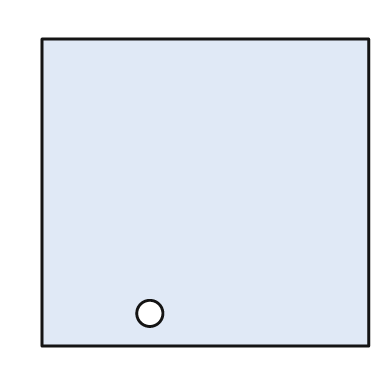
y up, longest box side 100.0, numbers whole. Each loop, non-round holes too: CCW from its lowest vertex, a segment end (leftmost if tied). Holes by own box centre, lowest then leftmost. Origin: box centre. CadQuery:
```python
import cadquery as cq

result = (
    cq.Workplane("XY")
    .moveTo(-50.0, -47.0)
    .lineTo(50.0, -47.0)
    .lineTo(50.0, 47.0)
    .lineTo(-50.0, 47.0)
    .close()
    .moveTo(-17.0, -37.0)
    .circle(4.0)
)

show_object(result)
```